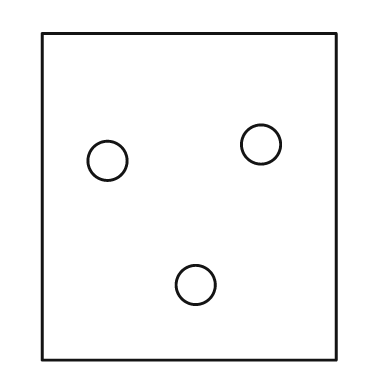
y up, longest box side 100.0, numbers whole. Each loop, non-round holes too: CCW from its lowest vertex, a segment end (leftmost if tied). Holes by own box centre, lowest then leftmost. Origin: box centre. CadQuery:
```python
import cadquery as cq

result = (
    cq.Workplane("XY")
    .moveTo(-45.0, -50.0)
    .lineTo(45.0, -50.0)
    .lineTo(45.0, 50.0)
    .lineTo(-45.0, 50.0)
    .close()
    .moveTo(2.0, -27.0)
    .circle(6.0)
    .moveTo(-25.0, 11.0)
    .circle(6.0)
    .moveTo(22.0, 16.0)
    .circle(6.0)
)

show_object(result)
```